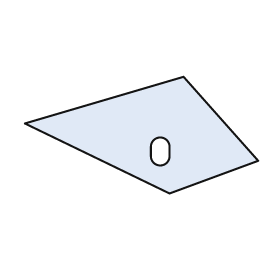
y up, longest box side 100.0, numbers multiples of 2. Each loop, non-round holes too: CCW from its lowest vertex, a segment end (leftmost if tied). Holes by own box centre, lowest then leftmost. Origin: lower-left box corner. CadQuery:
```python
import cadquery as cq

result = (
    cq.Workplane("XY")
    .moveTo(62.0, 0.0)
    .lineTo(100.0, 14.0)
    .lineTo(68.0, 50.0)
    .lineTo(0.0, 30.0)
    .close()
    .moveTo(54.0, 16.0)
    .threePointArc((58.0, 12.0), (62.0, 16.0))
    .lineTo(62.0, 20.0)
    .threePointArc((58.0, 24.0), (54.0, 20.0))
    .close()
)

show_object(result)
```